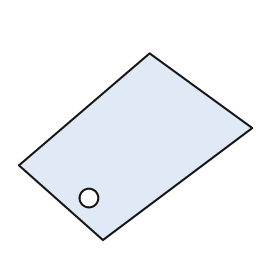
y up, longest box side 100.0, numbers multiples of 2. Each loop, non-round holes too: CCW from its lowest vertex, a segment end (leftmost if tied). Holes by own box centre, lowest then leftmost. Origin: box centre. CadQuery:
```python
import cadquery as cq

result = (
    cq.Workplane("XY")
    .moveTo(-14.0, -40.0)
    .lineTo(50.0, 8.0)
    .lineTo(6.0, 40.0)
    .lineTo(-50.0, -8.0)
    .close()
    .moveTo(-20.0, -22.0)
    .circle(4.0)
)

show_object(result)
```